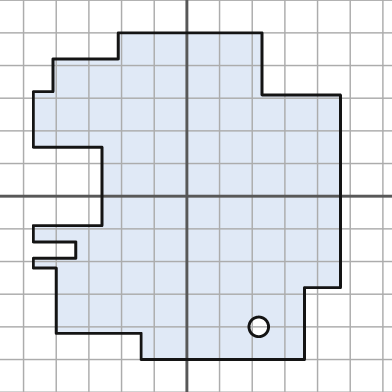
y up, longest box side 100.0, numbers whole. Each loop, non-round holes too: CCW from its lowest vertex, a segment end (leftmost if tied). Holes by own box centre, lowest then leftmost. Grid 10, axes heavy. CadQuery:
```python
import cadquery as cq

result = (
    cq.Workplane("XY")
    .moveTo(-14.0, -50.0)
    .lineTo(36.0, -50.0)
    .lineTo(36.0, -28.0)
    .lineTo(47.0, -28.0)
    .lineTo(47.0, 31.0)
    .lineTo(23.0, 31.0)
    .lineTo(23.0, 50.0)
    .lineTo(-21.0, 50.0)
    .lineTo(-21.0, 42.0)
    .lineTo(-41.0, 42.0)
    .lineTo(-41.0, 32.0)
    .lineTo(-47.0, 32.0)
    .lineTo(-47.0, 15.0)
    .lineTo(-26.0, 15.0)
    .lineTo(-26.0, -9.0)
    .lineTo(-47.0, -9.0)
    .lineTo(-47.0, -14.0)
    .lineTo(-34.0, -14.0)
    .lineTo(-34.0, -19.0)
    .lineTo(-47.0, -19.0)
    .lineTo(-47.0, -22.0)
    .lineTo(-40.0, -22.0)
    .lineTo(-40.0, -42.0)
    .lineTo(-14.0, -42.0)
    .close()
    .moveTo(22.0, -40.0)
    .circle(3.0)
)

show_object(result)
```